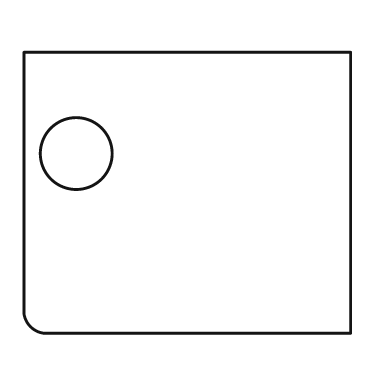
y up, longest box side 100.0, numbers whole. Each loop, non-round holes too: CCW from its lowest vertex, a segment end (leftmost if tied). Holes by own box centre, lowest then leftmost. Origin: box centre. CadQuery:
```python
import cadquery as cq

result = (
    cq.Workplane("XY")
    .moveTo(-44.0, -43.0)
    .lineTo(50.0, -43.0)
    .lineTo(50.0, 43.0)
    .lineTo(-50.0, 43.0)
    .lineTo(-50.0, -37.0)
    .threePointArc((-48.0, -41.0), (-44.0, -43.0))
    .close()
    .moveTo(-34.0, 12.0)
    .circle(11.0)
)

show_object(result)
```